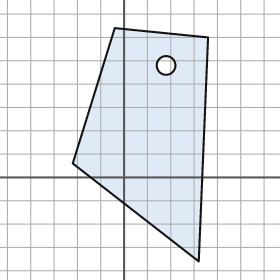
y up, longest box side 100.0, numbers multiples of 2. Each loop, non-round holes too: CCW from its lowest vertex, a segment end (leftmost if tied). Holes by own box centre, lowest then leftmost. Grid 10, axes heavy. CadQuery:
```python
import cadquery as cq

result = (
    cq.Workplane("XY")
    .moveTo(32.0, -36.0)
    .lineTo(36.0, 60.0)
    .lineTo(-4.0, 64.0)
    .lineTo(-22.0, 6.0)
    .close()
    .moveTo(18.0, 48.0)
    .circle(4.0)
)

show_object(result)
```